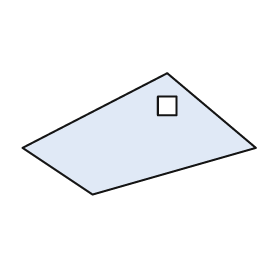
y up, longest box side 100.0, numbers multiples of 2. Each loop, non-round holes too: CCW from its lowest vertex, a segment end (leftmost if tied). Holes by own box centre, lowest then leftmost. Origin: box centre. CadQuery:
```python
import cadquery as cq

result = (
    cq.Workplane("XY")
    .moveTo(-20.0, -26.0)
    .lineTo(50.0, -6.0)
    .lineTo(12.0, 26.0)
    .lineTo(-50.0, -6.0)
    .close()
    .moveTo(8.0, 8.0)
    .lineTo(16.0, 8.0)
    .lineTo(16.0, 16.0)
    .lineTo(8.0, 16.0)
    .close()
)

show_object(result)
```